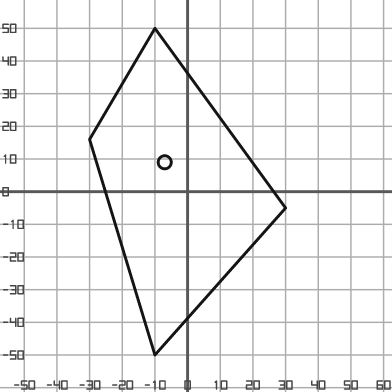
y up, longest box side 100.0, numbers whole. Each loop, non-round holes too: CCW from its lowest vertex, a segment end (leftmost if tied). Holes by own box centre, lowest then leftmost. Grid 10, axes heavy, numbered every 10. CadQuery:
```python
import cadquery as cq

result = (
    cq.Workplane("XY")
    .moveTo(-10.0, -50.0)
    .lineTo(30.0, -5.0)
    .lineTo(-10.0, 50.0)
    .lineTo(-30.0, 16.0)
    .close()
    .moveTo(-7.0, 9.0)
    .circle(2.0)
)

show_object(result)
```